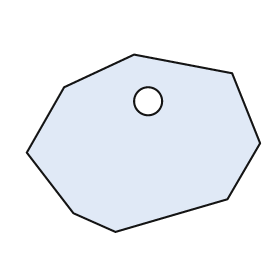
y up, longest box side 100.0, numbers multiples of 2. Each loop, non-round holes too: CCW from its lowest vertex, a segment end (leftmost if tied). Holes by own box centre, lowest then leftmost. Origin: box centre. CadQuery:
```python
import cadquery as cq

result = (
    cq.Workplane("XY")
    .moveTo(-12.0, -38.0)
    .lineTo(36.0, -24.0)
    .lineTo(50.0, 0.0)
    .lineTo(38.0, 30.0)
    .lineTo(-4.0, 38.0)
    .lineTo(-34.0, 24.0)
    .lineTo(-50.0, -4.0)
    .lineTo(-30.0, -30.0)
    .close()
    .moveTo(2.0, 18.0)
    .circle(6.0)
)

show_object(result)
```